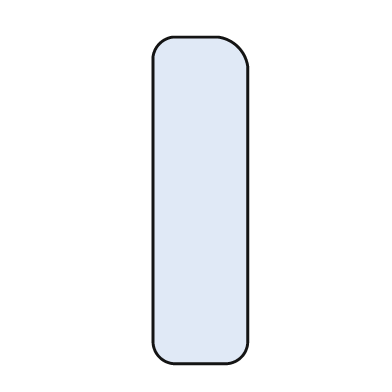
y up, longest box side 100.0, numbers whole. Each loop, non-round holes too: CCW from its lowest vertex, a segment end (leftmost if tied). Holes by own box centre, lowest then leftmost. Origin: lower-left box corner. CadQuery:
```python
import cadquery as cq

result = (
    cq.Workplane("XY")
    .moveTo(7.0, 0.0)
    .lineTo(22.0, 0.0)
    .threePointArc((27.0, 2.0), (29.0, 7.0))
    .lineTo(29.0, 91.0)
    .threePointArc((26.0, 97.0), (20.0, 100.0))
    .lineTo(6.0, 100.0)
    .threePointArc((2.0, 98.0), (0.0, 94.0))
    .lineTo(0.0, 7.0)
    .threePointArc((2.0, 2.0), (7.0, 0.0))
    .close()
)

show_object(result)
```